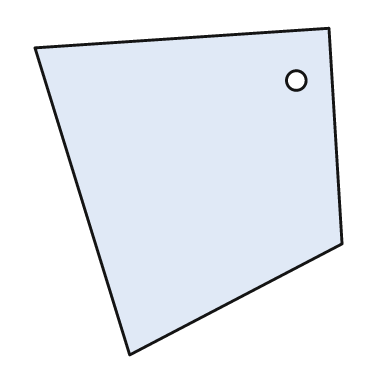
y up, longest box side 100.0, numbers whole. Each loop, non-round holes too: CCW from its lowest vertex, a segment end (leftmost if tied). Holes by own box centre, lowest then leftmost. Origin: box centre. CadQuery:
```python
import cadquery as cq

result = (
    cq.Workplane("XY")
    .moveTo(-18.0, -50.0)
    .lineTo(47.0, -16.0)
    .lineTo(43.0, 50.0)
    .lineTo(-47.0, 44.0)
    .close()
    .moveTo(33.0, 34.0)
    .circle(3.0)
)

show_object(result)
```